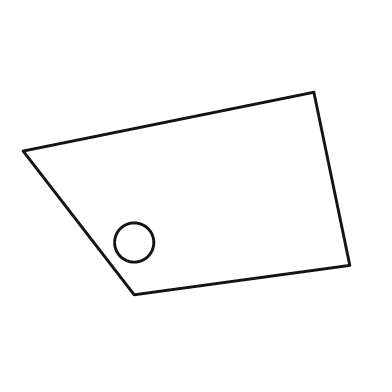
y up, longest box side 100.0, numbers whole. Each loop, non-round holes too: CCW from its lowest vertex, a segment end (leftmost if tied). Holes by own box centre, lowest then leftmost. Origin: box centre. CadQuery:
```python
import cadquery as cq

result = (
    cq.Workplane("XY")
    .moveTo(-16.0, -31.0)
    .lineTo(50.0, -22.0)
    .lineTo(39.0, 31.0)
    .lineTo(-50.0, 13.0)
    .close()
    .moveTo(-16.0, -15.0)
    .circle(6.0)
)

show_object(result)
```